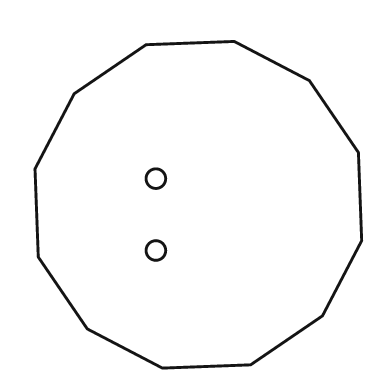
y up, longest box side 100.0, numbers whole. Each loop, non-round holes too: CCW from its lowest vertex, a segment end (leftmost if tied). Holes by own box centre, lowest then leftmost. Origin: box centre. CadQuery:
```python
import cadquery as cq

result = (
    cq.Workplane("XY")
    .moveTo(-11.0, -50.0)
    .lineTo(16.0, -49.0)
    .lineTo(38.0, -34.0)
    .lineTo(50.0, -11.0)
    .lineTo(49.0, 16.0)
    .lineTo(34.0, 38.0)
    .lineTo(11.0, 50.0)
    .lineTo(-16.0, 49.0)
    .lineTo(-38.0, 34.0)
    .lineTo(-50.0, 11.0)
    .lineTo(-49.0, -16.0)
    .lineTo(-34.0, -38.0)
    .close()
    .moveTo(-13.0, -14.0)
    .circle(3.0)
    .moveTo(-13.0, 8.0)
    .circle(3.0)
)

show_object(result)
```